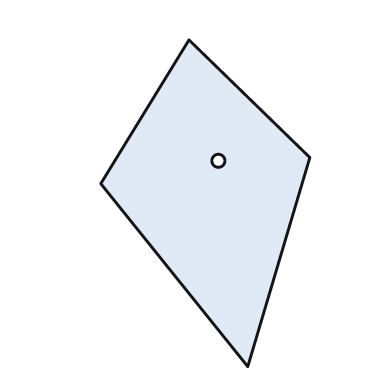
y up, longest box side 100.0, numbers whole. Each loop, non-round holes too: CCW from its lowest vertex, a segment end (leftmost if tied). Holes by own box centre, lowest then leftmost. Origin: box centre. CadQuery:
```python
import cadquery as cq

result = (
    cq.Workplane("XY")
    .moveTo(13.0, -50.0)
    .lineTo(32.0, 14.0)
    .lineTo(-5.0, 50.0)
    .lineTo(-32.0, 6.0)
    .close()
    .moveTo(4.0, 13.0)
    .circle(2.0)
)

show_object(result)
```